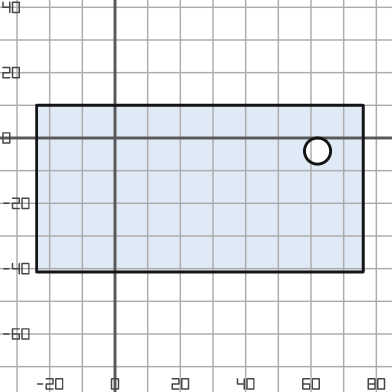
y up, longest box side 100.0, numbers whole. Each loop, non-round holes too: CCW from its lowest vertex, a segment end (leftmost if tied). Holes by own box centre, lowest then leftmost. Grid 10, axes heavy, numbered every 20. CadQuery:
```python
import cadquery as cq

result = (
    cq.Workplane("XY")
    .moveTo(-24.0, -41.0)
    .lineTo(76.0, -41.0)
    .lineTo(76.0, 10.0)
    .lineTo(-24.0, 10.0)
    .close()
    .moveTo(62.0, -4.0)
    .circle(4.0)
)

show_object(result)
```